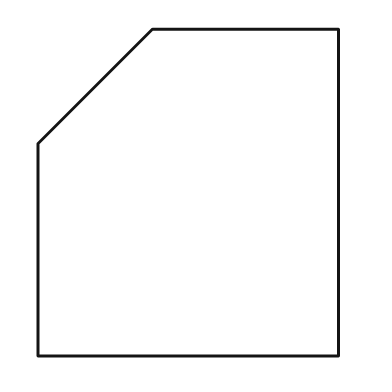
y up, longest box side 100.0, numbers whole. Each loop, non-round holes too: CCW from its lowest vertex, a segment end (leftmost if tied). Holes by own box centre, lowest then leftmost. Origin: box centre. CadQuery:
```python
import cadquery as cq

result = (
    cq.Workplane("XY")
    .moveTo(-46.0, -50.0)
    .lineTo(46.0, -50.0)
    .lineTo(46.0, 50.0)
    .lineTo(-11.0, 50.0)
    .lineTo(-46.0, 15.0)
    .close()
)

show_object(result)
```